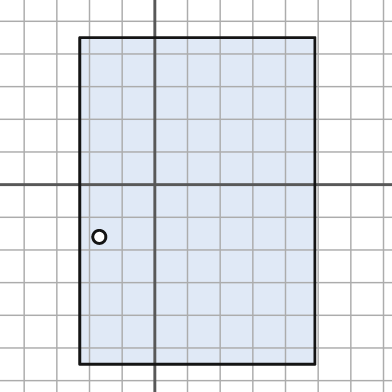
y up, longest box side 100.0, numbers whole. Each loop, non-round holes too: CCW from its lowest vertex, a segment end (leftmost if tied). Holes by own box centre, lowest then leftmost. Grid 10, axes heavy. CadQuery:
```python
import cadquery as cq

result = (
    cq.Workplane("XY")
    .moveTo(-23.0, -55.0)
    .lineTo(49.0, -55.0)
    .lineTo(49.0, 45.0)
    .lineTo(-23.0, 45.0)
    .close()
    .moveTo(-17.0, -16.0)
    .circle(2.0)
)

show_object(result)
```